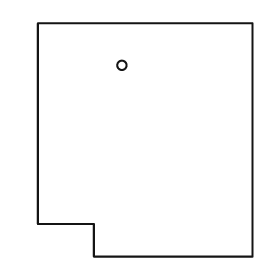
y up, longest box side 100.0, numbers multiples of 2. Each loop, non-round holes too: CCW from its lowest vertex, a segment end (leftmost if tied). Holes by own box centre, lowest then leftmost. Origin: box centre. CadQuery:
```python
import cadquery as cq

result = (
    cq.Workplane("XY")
    .moveTo(-22.0, -50.0)
    .lineTo(46.0, -50.0)
    .lineTo(46.0, 50.0)
    .lineTo(-46.0, 50.0)
    .lineTo(-46.0, -36.0)
    .lineTo(-22.0, -36.0)
    .close()
    .moveTo(-10.0, 32.0)
    .circle(2.0)
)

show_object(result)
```